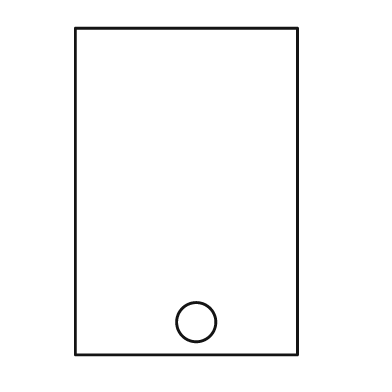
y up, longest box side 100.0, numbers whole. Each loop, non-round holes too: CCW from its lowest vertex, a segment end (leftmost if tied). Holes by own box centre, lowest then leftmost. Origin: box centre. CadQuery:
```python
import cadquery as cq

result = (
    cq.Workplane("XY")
    .moveTo(-34.0, -50.0)
    .lineTo(34.0, -50.0)
    .lineTo(34.0, 50.0)
    .lineTo(-34.0, 50.0)
    .close()
    .moveTo(3.0, -40.0)
    .circle(6.0)
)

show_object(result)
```